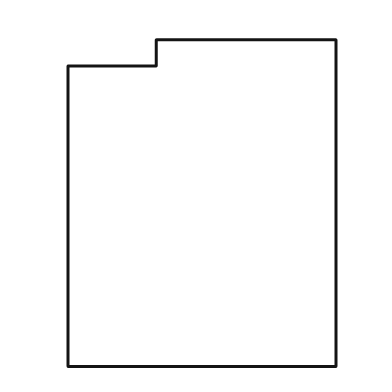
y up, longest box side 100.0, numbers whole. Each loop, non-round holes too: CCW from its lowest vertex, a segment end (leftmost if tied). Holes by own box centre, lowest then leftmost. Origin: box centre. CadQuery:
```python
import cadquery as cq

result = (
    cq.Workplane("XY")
    .moveTo(-41.0, -50.0)
    .lineTo(41.0, -50.0)
    .lineTo(41.0, 50.0)
    .lineTo(-14.0, 50.0)
    .lineTo(-14.0, 42.0)
    .lineTo(-41.0, 42.0)
    .close()
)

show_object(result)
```